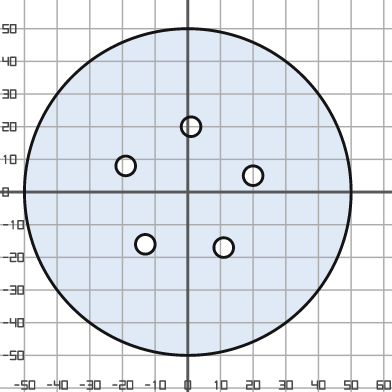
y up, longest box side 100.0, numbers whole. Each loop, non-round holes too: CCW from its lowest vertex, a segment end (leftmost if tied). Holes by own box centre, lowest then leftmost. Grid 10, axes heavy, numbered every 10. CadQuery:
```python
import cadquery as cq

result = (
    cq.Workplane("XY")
    .moveTo(0.0, 0.0)
    .circle(50.0)
    .moveTo(11.0, -17.0)
    .circle(3.0)
    .moveTo(-13.0, -16.0)
    .circle(3.0)
    .moveTo(20.0, 5.0)
    .circle(3.0)
    .moveTo(-19.0, 8.0)
    .circle(3.0)
    .moveTo(1.0, 20.0)
    .circle(3.0)
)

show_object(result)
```